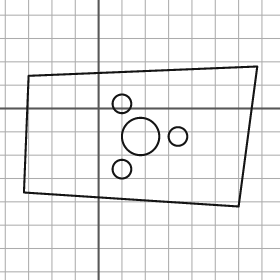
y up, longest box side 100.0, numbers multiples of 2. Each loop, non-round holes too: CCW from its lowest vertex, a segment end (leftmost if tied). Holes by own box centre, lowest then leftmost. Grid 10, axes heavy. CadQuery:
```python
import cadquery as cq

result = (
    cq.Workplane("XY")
    .moveTo(60.0, -42.0)
    .lineTo(68.0, 18.0)
    .lineTo(-30.0, 14.0)
    .lineTo(-32.0, -36.0)
    .close()
    .moveTo(10.0, -26.0)
    .circle(4.0)
    .moveTo(18.0, -12.0)
    .circle(8.0)
    .moveTo(34.0, -12.0)
    .circle(4.0)
    .moveTo(10.0, 2.0)
    .circle(4.0)
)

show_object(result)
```